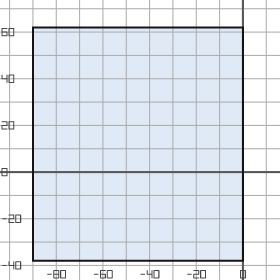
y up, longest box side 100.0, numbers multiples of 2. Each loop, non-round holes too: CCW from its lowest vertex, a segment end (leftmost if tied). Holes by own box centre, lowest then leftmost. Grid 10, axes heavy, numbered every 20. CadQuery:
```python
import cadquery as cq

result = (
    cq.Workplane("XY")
    .moveTo(-90.0, -38.0)
    .lineTo(0.0, -38.0)
    .lineTo(0.0, 62.0)
    .lineTo(-90.0, 62.0)
    .close()
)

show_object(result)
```